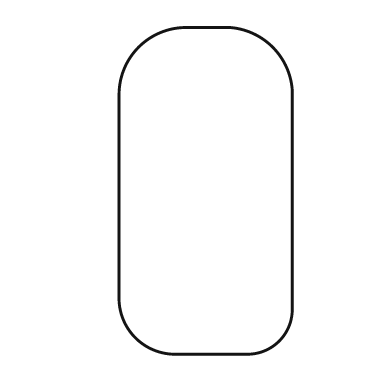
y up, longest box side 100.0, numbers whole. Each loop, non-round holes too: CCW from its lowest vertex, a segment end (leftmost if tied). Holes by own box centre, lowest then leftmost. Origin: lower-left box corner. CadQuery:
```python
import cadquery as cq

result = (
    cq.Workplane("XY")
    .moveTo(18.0, 0.0)
    .lineTo(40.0, 0.0)
    .threePointArc((49.0, 4.0), (53.0, 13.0))
    .lineTo(53.0, 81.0)
    .threePointArc((47.0, 94.0), (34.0, 100.0))
    .lineTo(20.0, 100.0)
    .threePointArc((6.0, 94.0), (0.0, 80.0))
    .lineTo(0.0, 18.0)
    .threePointArc((5.0, 5.0), (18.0, 0.0))
    .close()
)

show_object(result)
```